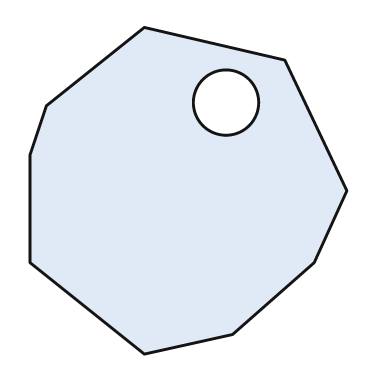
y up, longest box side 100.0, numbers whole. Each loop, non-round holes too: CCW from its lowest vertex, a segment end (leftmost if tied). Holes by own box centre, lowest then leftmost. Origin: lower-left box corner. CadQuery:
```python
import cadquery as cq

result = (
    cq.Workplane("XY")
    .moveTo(35.0, 0.0)
    .lineTo(62.0, 6.0)
    .lineTo(87.0, 28.0)
    .lineTo(97.0, 50.0)
    .lineTo(78.0, 90.0)
    .lineTo(35.0, 100.0)
    .lineTo(5.0, 76.0)
    .lineTo(0.0, 61.0)
    .lineTo(0.0, 28.0)
    .close()
    .moveTo(60.0, 77.0)
    .circle(10.0)
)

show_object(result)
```